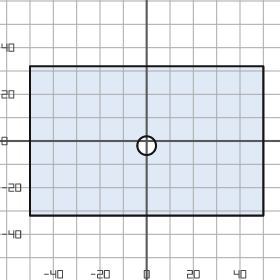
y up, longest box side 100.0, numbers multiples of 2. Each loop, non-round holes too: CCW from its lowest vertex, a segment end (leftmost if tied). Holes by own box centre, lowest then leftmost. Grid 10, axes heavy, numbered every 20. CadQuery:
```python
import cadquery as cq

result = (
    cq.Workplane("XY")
    .moveTo(-50.0, -32.0)
    .lineTo(50.0, -32.0)
    .lineTo(50.0, 32.0)
    .lineTo(-50.0, 32.0)
    .close()
    .moveTo(0.0, -2.0)
    .circle(4.0)
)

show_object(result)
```